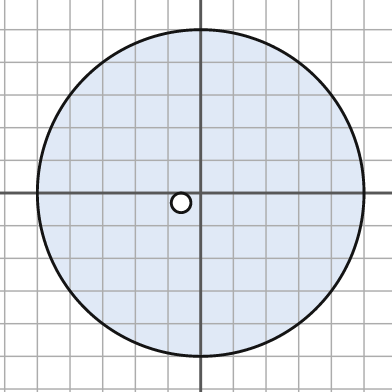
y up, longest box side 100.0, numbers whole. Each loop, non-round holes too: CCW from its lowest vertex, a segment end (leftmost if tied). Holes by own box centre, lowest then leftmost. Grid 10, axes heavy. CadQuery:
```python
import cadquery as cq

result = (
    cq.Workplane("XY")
    .moveTo(0.0, 0.0)
    .circle(50.0)
    .moveTo(-6.0, -3.0)
    .circle(3.0)
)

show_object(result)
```